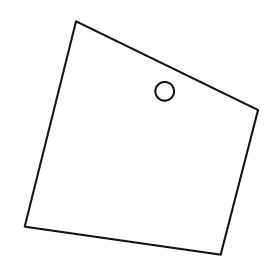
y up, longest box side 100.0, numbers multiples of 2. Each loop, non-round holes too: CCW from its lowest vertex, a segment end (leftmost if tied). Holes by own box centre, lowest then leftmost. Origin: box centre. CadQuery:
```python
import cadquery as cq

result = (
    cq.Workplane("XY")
    .moveTo(34.0, -50.0)
    .lineTo(50.0, 12.0)
    .lineTo(-28.0, 50.0)
    .lineTo(-50.0, -38.0)
    .close()
    .moveTo(10.0, 20.0)
    .circle(4.0)
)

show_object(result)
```